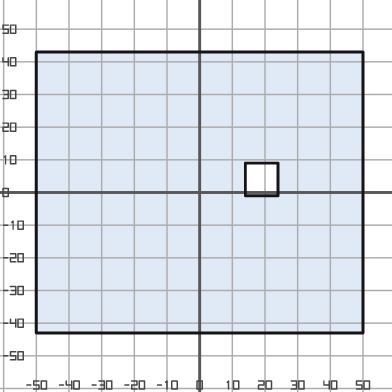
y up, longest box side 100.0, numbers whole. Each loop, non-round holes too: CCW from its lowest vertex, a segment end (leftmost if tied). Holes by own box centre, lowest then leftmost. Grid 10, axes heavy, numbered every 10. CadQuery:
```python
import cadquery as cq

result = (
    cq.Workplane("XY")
    .moveTo(-50.0, -43.0)
    .lineTo(50.0, -43.0)
    .lineTo(50.0, 43.0)
    .lineTo(-50.0, 43.0)
    .close()
    .moveTo(14.0, -1.0)
    .lineTo(24.0, -1.0)
    .lineTo(24.0, 9.0)
    .lineTo(14.0, 9.0)
    .close()
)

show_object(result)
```